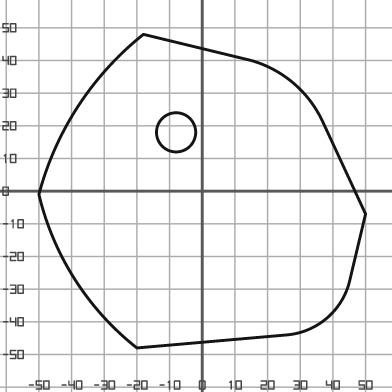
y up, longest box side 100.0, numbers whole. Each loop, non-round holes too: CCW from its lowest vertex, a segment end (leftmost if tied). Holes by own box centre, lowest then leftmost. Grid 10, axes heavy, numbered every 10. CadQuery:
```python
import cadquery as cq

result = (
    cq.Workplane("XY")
    .moveTo(-20.0, -48.0)
    .lineTo(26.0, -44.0)
    .threePointArc((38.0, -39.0), (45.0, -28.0))
    .lineTo(50.0, -7.0)
    .lineTo(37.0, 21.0)
    .threePointArc((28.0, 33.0), (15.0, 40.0))
    .lineTo(-18.0, 48.0)
    .threePointArc((-38.0, 26.0), (-50.0, -1.0))
    .threePointArc((-39.0, -27.0), (-20.0, -48.0))
    .close()
    .moveTo(-8.0, 18.0)
    .circle(6.0)
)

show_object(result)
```